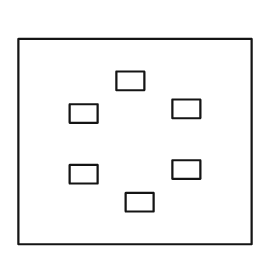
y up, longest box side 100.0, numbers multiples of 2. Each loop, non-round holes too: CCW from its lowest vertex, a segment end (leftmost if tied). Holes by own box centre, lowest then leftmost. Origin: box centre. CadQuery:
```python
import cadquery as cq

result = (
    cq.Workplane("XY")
    .moveTo(-50.0, -44.0)
    .lineTo(50.0, -44.0)
    .lineTo(50.0, 44.0)
    .lineTo(-50.0, 44.0)
    .close()
    .moveTo(-4.0, -30.0)
    .lineTo(8.0, -30.0)
    .lineTo(8.0, -22.0)
    .lineTo(-4.0, -22.0)
    .close()
    .moveTo(-28.0, -18.0)
    .lineTo(-16.0, -18.0)
    .lineTo(-16.0, -10.0)
    .lineTo(-28.0, -10.0)
    .close()
    .moveTo(16.0, -16.0)
    .lineTo(28.0, -16.0)
    .lineTo(28.0, -8.0)
    .lineTo(16.0, -8.0)
    .close()
    .moveTo(-28.0, 8.0)
    .lineTo(-16.0, 8.0)
    .lineTo(-16.0, 16.0)
    .lineTo(-28.0, 16.0)
    .close()
    .moveTo(16.0, 10.0)
    .lineTo(28.0, 10.0)
    .lineTo(28.0, 18.0)
    .lineTo(16.0, 18.0)
    .close()
    .moveTo(-8.0, 22.0)
    .lineTo(4.0, 22.0)
    .lineTo(4.0, 30.0)
    .lineTo(-8.0, 30.0)
    .close()
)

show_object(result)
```